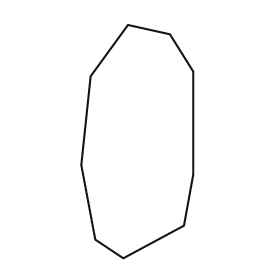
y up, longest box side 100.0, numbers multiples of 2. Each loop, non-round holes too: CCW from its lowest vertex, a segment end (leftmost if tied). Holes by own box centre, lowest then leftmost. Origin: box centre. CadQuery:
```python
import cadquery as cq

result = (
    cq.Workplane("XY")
    .moveTo(-6.0, -50.0)
    .lineTo(20.0, -36.0)
    .lineTo(24.0, -14.0)
    .lineTo(24.0, 30.0)
    .lineTo(14.0, 46.0)
    .lineTo(-4.0, 50.0)
    .lineTo(-20.0, 28.0)
    .lineTo(-24.0, -10.0)
    .lineTo(-18.0, -42.0)
    .close()
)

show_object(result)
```